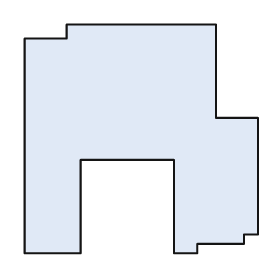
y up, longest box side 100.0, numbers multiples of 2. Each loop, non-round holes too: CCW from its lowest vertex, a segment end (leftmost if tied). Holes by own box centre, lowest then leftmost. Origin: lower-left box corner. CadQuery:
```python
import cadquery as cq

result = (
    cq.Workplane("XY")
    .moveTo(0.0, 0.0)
    .lineTo(24.0, 0.0)
    .lineTo(24.0, 40.0)
    .lineTo(64.0, 40.0)
    .lineTo(64.0, 0.0)
    .lineTo(74.0, 0.0)
    .lineTo(74.0, 4.0)
    .lineTo(94.0, 4.0)
    .lineTo(94.0, 8.0)
    .lineTo(100.0, 8.0)
    .lineTo(100.0, 58.0)
    .lineTo(82.0, 58.0)
    .lineTo(82.0, 98.0)
    .lineTo(18.0, 98.0)
    .lineTo(18.0, 92.0)
    .lineTo(0.0, 92.0)
    .close()
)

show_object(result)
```